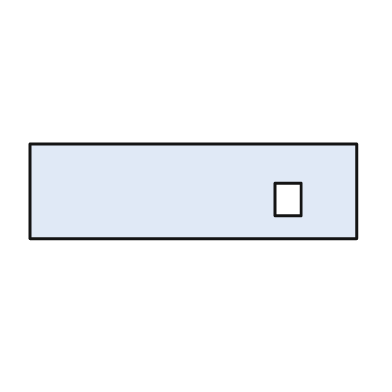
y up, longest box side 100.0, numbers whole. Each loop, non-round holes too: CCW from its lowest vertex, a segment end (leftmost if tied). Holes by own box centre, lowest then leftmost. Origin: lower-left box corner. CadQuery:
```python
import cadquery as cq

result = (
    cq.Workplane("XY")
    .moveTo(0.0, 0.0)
    .lineTo(100.0, 0.0)
    .lineTo(100.0, 29.0)
    .lineTo(0.0, 29.0)
    .close()
    .moveTo(75.0, 7.0)
    .lineTo(83.0, 7.0)
    .lineTo(83.0, 17.0)
    .lineTo(75.0, 17.0)
    .close()
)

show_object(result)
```